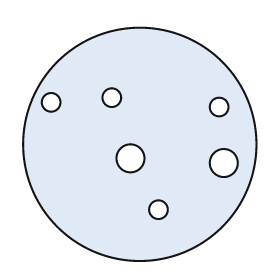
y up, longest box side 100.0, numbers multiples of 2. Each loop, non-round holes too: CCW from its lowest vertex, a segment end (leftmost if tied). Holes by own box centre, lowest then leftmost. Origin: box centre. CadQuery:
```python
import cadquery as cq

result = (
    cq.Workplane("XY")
    .moveTo(0.0, 0.0)
    .circle(50.0)
    .moveTo(8.0, -28.0)
    .circle(4.0)
    .moveTo(36.0, -8.0)
    .circle(6.0)
    .moveTo(-4.0, -6.0)
    .circle(6.0)
    .moveTo(34.0, 16.0)
    .circle(4.0)
    .moveTo(-38.0, 18.0)
    .circle(4.0)
    .moveTo(-12.0, 20.0)
    .circle(4.0)
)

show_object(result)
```